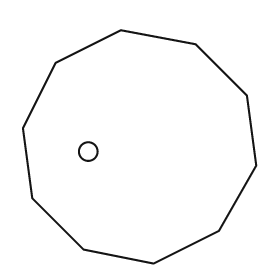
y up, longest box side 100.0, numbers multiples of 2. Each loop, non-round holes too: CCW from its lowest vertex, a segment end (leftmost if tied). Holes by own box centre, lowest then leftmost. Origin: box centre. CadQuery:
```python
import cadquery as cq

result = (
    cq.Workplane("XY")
    .moveTo(6.0, -50.0)
    .lineTo(34.0, -36.0)
    .lineTo(50.0, -8.0)
    .lineTo(46.0, 22.0)
    .lineTo(24.0, 44.0)
    .lineTo(-8.0, 50.0)
    .lineTo(-36.0, 36.0)
    .lineTo(-50.0, 8.0)
    .lineTo(-46.0, -22.0)
    .lineTo(-24.0, -44.0)
    .close()
    .moveTo(-22.0, -2.0)
    .circle(4.0)
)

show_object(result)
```